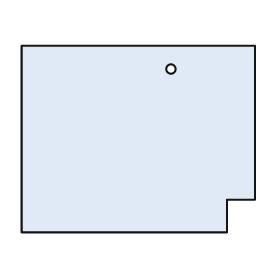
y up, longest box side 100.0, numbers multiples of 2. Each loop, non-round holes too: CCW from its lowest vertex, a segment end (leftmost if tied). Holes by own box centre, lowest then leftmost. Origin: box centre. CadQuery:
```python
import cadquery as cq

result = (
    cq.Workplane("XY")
    .moveTo(-50.0, -40.0)
    .lineTo(38.0, -40.0)
    .lineTo(38.0, -26.0)
    .lineTo(50.0, -26.0)
    .lineTo(50.0, 40.0)
    .lineTo(-50.0, 40.0)
    .close()
    .moveTo(14.0, 30.0)
    .circle(2.0)
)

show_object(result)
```